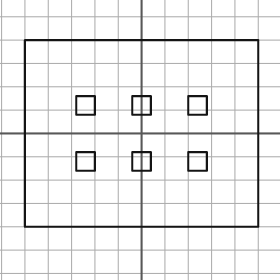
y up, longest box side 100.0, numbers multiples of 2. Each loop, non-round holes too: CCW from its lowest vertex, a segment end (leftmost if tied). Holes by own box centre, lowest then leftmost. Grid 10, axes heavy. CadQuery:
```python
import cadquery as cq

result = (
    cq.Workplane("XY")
    .moveTo(-50.0, -40.0)
    .lineTo(50.0, -40.0)
    .lineTo(50.0, 40.0)
    .lineTo(-50.0, 40.0)
    .close()
    .moveTo(-28.0, -16.0)
    .lineTo(-20.0, -16.0)
    .lineTo(-20.0, -8.0)
    .lineTo(-28.0, -8.0)
    .close()
    .moveTo(-4.0, -16.0)
    .lineTo(4.0, -16.0)
    .lineTo(4.0, -8.0)
    .lineTo(-4.0, -8.0)
    .close()
    .moveTo(20.0, -16.0)
    .lineTo(28.0, -16.0)
    .lineTo(28.0, -8.0)
    .lineTo(20.0, -8.0)
    .close()
    .moveTo(-28.0, 8.0)
    .lineTo(-20.0, 8.0)
    .lineTo(-20.0, 16.0)
    .lineTo(-28.0, 16.0)
    .close()
    .moveTo(-4.0, 8.0)
    .lineTo(4.0, 8.0)
    .lineTo(4.0, 16.0)
    .lineTo(-4.0, 16.0)
    .close()
    .moveTo(20.0, 8.0)
    .lineTo(28.0, 8.0)
    .lineTo(28.0, 16.0)
    .lineTo(20.0, 16.0)
    .close()
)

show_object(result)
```